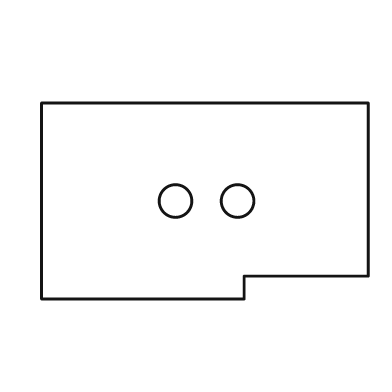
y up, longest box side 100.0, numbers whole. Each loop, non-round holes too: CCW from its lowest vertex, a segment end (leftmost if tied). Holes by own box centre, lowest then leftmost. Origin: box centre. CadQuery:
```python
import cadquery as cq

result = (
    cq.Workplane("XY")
    .moveTo(-50.0, -30.0)
    .lineTo(12.0, -30.0)
    .lineTo(12.0, -23.0)
    .lineTo(50.0, -23.0)
    .lineTo(50.0, 30.0)
    .lineTo(-50.0, 30.0)
    .close()
    .moveTo(-9.0, 0.0)
    .circle(5.0)
    .moveTo(10.0, 0.0)
    .circle(5.0)
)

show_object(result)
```